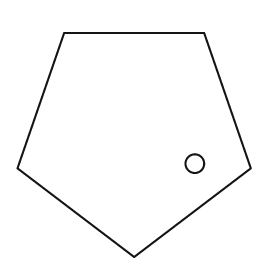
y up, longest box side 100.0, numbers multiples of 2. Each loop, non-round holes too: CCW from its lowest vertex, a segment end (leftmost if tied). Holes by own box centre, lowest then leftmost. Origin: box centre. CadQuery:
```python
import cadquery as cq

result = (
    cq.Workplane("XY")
    .moveTo(0.0, -48.0)
    .lineTo(50.0, -10.0)
    .lineTo(30.0, 48.0)
    .lineTo(-30.0, 48.0)
    .lineTo(-50.0, -10.0)
    .close()
    .moveTo(26.0, -8.0)
    .circle(4.0)
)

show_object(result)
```